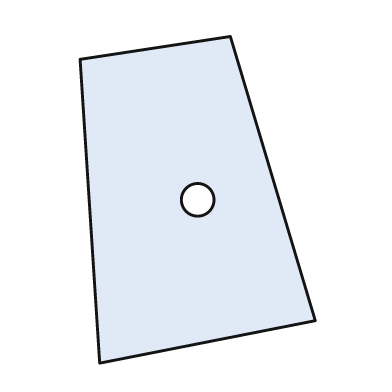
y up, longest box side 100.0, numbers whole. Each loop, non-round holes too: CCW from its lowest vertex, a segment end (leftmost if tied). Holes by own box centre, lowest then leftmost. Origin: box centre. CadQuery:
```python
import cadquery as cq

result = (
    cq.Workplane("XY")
    .moveTo(-30.0, -50.0)
    .lineTo(36.0, -37.0)
    .lineTo(10.0, 50.0)
    .lineTo(-36.0, 43.0)
    .close()
    .moveTo(0.0, 0.0)
    .circle(5.0)
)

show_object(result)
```